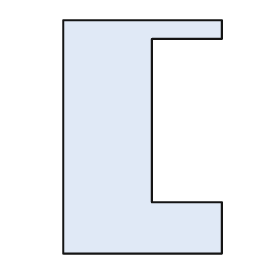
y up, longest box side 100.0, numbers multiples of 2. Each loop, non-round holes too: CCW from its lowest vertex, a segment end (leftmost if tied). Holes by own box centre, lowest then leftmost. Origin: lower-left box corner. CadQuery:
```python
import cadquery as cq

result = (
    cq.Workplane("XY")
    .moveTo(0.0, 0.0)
    .lineTo(68.0, 0.0)
    .lineTo(68.0, 22.0)
    .lineTo(38.0, 22.0)
    .lineTo(38.0, 92.0)
    .lineTo(68.0, 92.0)
    .lineTo(68.0, 100.0)
    .lineTo(0.0, 100.0)
    .close()
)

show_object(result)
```